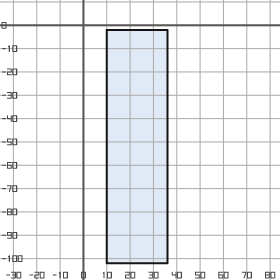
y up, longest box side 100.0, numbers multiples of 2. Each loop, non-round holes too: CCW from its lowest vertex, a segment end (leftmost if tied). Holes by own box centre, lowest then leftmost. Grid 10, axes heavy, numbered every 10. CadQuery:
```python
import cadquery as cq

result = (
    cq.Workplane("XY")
    .moveTo(10.0, -102.0)
    .lineTo(36.0, -102.0)
    .lineTo(36.0, -2.0)
    .lineTo(10.0, -2.0)
    .close()
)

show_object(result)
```